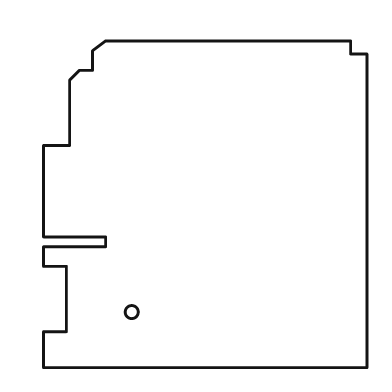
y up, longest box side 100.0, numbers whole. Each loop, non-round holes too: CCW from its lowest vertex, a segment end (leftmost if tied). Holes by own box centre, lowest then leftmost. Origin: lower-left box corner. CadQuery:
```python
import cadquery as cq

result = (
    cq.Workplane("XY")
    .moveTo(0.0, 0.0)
    .lineTo(99.0, 0.0)
    .lineTo(99.0, 96.0)
    .lineTo(94.0, 96.0)
    .lineTo(94.0, 100.0)
    .lineTo(19.0, 100.0)
    .lineTo(15.0, 97.0)
    .lineTo(15.0, 91.0)
    .lineTo(11.0, 91.0)
    .lineTo(8.0, 88.0)
    .lineTo(8.0, 68.0)
    .lineTo(0.0, 68.0)
    .lineTo(0.0, 40.0)
    .lineTo(19.0, 40.0)
    .lineTo(19.0, 37.0)
    .lineTo(0.0, 37.0)
    .lineTo(0.0, 31.0)
    .lineTo(7.0, 31.0)
    .lineTo(7.0, 11.0)
    .lineTo(0.0, 11.0)
    .close()
    .moveTo(27.0, 17.0)
    .circle(2.0)
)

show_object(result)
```